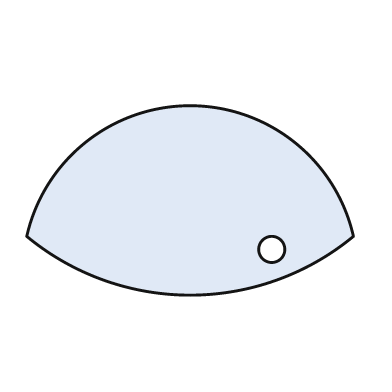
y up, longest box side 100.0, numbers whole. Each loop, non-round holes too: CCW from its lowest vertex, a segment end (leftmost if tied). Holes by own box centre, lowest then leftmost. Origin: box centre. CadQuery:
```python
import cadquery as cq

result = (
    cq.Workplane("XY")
    .moveTo(-50.0, -11.0)
    .threePointArc((0.0, -29.0), (50.0, -11.0))
    .threePointArc((0.0, 29.0), (-50.0, -11.0))
    .close()
    .moveTo(25.0, -15.0)
    .circle(4.0)
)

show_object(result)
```